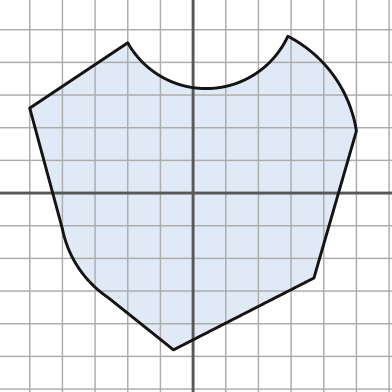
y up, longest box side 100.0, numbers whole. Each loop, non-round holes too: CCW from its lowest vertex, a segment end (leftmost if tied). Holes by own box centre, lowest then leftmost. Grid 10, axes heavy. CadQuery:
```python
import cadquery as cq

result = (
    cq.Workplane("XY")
    .moveTo(-6.0, -48.0)
    .lineTo(37.0, -26.0)
    .lineTo(50.0, 19.0)
    .threePointArc((43.0, 36.0), (29.0, 48.0))
    .threePointArc((5.0, 32.0), (-20.0, 46.0))
    .lineTo(-50.0, 26.0)
    .lineTo(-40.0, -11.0)
    .threePointArc((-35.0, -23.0), (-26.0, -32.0))
    .close()
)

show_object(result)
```